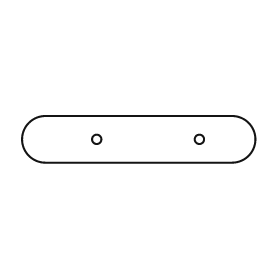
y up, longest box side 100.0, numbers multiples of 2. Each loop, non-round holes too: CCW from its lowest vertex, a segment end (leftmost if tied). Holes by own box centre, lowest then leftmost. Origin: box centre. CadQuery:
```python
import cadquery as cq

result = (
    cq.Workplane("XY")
    .moveTo(-40.0, -10.0)
    .lineTo(40.0, -10.0)
    .threePointArc((50.0, 0.0), (40.0, 10.0))
    .lineTo(-40.0, 10.0)
    .threePointArc((-50.0, 0.0), (-40.0, -10.0))
    .close()
    .moveTo(-18.0, 0.0)
    .circle(2.0)
    .moveTo(26.0, 0.0)
    .circle(2.0)
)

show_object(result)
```